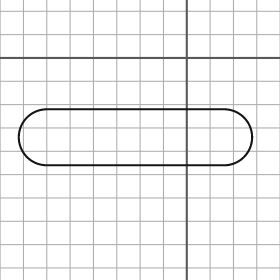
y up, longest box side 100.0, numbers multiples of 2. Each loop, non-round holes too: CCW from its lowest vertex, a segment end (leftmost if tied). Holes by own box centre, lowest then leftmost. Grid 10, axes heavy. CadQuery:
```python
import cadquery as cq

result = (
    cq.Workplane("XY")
    .moveTo(-60.0, -46.0)
    .lineTo(16.0, -46.0)
    .threePointArc((28.0, -34.0), (16.0, -22.0))
    .lineTo(-60.0, -22.0)
    .threePointArc((-72.0, -34.0), (-60.0, -46.0))
    .close()
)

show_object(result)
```